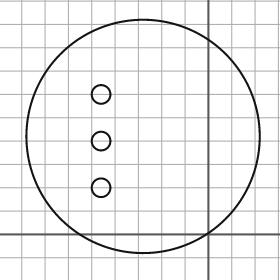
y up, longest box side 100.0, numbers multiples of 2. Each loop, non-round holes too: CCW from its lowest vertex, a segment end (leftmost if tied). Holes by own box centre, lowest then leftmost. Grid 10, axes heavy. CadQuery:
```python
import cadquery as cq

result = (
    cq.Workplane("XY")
    .moveTo(-28.0, 42.0)
    .circle(50.0)
    .moveTo(-46.0, 20.0)
    .circle(4.0)
    .moveTo(-46.0, 40.0)
    .circle(4.0)
    .moveTo(-46.0, 60.0)
    .circle(4.0)
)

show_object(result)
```